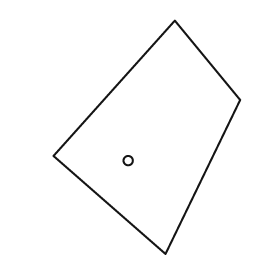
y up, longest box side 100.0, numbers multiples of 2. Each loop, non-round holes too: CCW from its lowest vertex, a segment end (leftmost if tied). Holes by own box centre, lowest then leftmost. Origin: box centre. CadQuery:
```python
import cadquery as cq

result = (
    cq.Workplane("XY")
    .moveTo(8.0, -50.0)
    .lineTo(40.0, 16.0)
    .lineTo(12.0, 50.0)
    .lineTo(-40.0, -8.0)
    .close()
    .moveTo(-8.0, -10.0)
    .circle(2.0)
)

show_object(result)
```